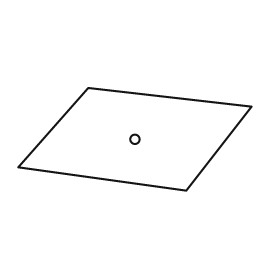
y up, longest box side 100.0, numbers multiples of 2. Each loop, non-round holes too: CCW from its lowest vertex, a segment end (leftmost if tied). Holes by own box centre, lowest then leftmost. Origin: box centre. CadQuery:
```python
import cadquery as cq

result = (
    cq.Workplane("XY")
    .moveTo(22.0, -22.0)
    .lineTo(50.0, 14.0)
    .lineTo(-20.0, 22.0)
    .lineTo(-50.0, -12.0)
    .close()
    .moveTo(0.0, 0.0)
    .circle(2.0)
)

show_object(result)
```